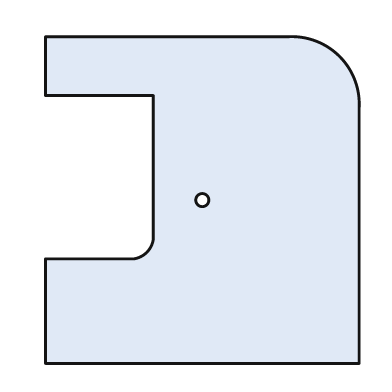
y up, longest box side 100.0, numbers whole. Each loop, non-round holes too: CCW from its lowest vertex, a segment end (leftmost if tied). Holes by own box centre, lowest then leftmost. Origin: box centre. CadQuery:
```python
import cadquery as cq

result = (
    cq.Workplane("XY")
    .moveTo(-48.0, -50.0)
    .lineTo(48.0, -50.0)
    .lineTo(48.0, 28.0)
    .threePointArc((42.0, 44.0), (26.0, 50.0))
    .lineTo(-48.0, 50.0)
    .lineTo(-48.0, 32.0)
    .lineTo(-15.0, 32.0)
    .lineTo(-15.0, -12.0)
    .threePointArc((-17.0, -16.0), (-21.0, -18.0))
    .lineTo(-48.0, -18.0)
    .close()
    .moveTo(0.0, 0.0)
    .circle(2.0)
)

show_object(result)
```